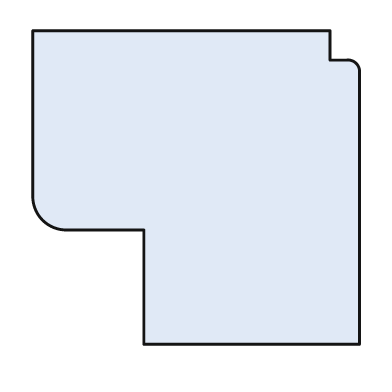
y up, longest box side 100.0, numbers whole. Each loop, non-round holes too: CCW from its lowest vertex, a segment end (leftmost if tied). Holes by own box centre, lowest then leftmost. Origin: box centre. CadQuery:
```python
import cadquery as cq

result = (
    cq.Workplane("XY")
    .moveTo(-16.0, -48.0)
    .lineTo(50.0, -48.0)
    .lineTo(50.0, 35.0)
    .threePointArc((49.0, 38.0), (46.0, 39.0))
    .lineTo(41.0, 39.0)
    .lineTo(41.0, 48.0)
    .lineTo(-50.0, 48.0)
    .lineTo(-50.0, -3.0)
    .threePointArc((-47.0, -10.0), (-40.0, -13.0))
    .lineTo(-16.0, -13.0)
    .close()
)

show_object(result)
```